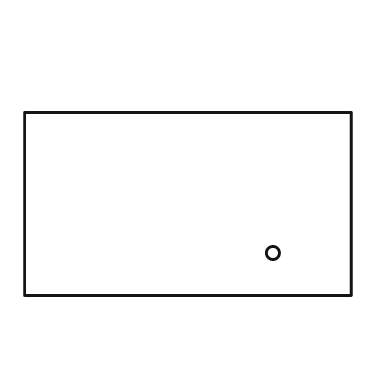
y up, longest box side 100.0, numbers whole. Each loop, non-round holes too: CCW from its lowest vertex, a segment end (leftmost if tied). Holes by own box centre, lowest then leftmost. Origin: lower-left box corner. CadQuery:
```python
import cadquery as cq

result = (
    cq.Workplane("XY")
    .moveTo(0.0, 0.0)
    .lineTo(100.0, 0.0)
    .lineTo(100.0, 56.0)
    .lineTo(0.0, 56.0)
    .close()
    .moveTo(76.0, 13.0)
    .circle(2.0)
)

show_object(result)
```